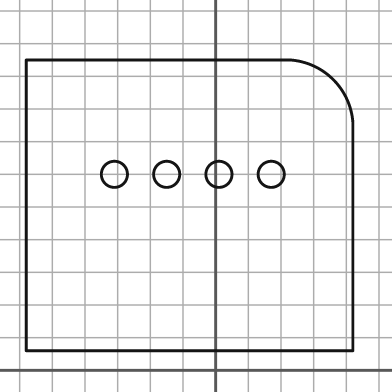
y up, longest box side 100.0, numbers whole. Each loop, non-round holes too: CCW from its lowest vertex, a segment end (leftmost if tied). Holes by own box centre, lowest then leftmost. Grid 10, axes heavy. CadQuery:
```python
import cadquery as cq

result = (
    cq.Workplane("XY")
    .moveTo(-58.0, 6.0)
    .lineTo(42.0, 6.0)
    .lineTo(42.0, 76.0)
    .threePointArc((36.0, 89.0), (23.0, 95.0))
    .lineTo(-58.0, 95.0)
    .close()
    .moveTo(-31.0, 60.0)
    .circle(4.0)
    .moveTo(-15.0, 60.0)
    .circle(4.0)
    .moveTo(1.0, 60.0)
    .circle(4.0)
    .moveTo(17.0, 60.0)
    .circle(4.0)
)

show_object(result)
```